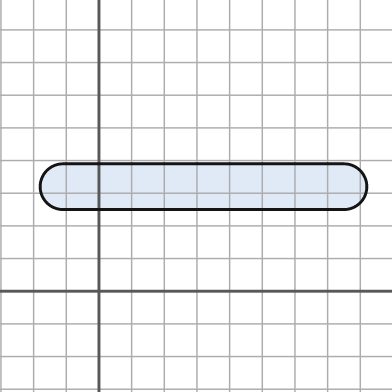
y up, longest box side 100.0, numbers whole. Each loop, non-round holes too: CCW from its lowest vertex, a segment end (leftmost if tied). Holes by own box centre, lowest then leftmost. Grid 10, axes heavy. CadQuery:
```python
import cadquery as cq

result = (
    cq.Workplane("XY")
    .moveTo(-11.0, 25.0)
    .lineTo(75.0, 25.0)
    .threePointArc((82.0, 32.0), (75.0, 39.0))
    .lineTo(-11.0, 39.0)
    .threePointArc((-18.0, 32.0), (-11.0, 25.0))
    .close()
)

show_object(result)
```